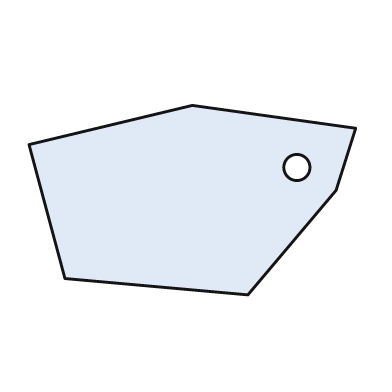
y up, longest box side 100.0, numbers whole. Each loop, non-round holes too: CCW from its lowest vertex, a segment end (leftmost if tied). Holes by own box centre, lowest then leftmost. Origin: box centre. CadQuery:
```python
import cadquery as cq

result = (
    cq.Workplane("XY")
    .moveTo(17.0, -29.0)
    .lineTo(44.0, 3.0)
    .lineTo(50.0, 22.0)
    .lineTo(0.0, 29.0)
    .lineTo(-50.0, 17.0)
    .lineTo(-39.0, -24.0)
    .close()
    .moveTo(32.0, 10.0)
    .circle(4.0)
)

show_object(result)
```